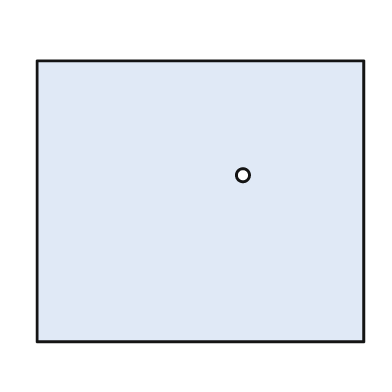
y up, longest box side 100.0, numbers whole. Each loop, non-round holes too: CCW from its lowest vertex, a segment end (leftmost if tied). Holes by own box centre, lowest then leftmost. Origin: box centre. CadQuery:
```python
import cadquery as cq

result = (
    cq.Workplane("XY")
    .moveTo(-50.0, -43.0)
    .lineTo(50.0, -43.0)
    .lineTo(50.0, 43.0)
    .lineTo(-50.0, 43.0)
    .close()
    .moveTo(13.0, 8.0)
    .circle(2.0)
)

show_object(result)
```